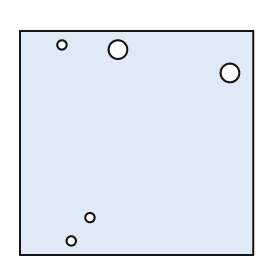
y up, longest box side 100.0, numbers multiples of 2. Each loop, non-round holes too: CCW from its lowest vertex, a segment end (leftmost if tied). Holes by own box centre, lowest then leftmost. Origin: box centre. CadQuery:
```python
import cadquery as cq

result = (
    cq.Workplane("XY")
    .moveTo(-50.0, -48.0)
    .lineTo(50.0, -48.0)
    .lineTo(50.0, 48.0)
    .lineTo(-50.0, 48.0)
    .close()
    .moveTo(-28.0, -42.0)
    .circle(2.0)
    .moveTo(-20.0, -32.0)
    .circle(2.0)
    .moveTo(40.0, 30.0)
    .circle(4.0)
    .moveTo(-8.0, 40.0)
    .circle(4.0)
    .moveTo(-32.0, 42.0)
    .circle(2.0)
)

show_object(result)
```